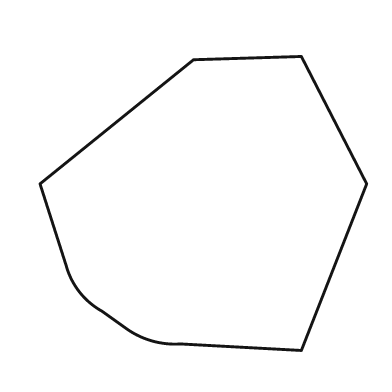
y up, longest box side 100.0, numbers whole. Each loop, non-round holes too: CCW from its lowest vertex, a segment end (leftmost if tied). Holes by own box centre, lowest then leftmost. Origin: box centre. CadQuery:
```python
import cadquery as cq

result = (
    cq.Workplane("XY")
    .moveTo(30.0, -45.0)
    .lineTo(50.0, 6.0)
    .lineTo(30.0, 45.0)
    .lineTo(-3.0, 44.0)
    .lineTo(-50.0, 6.0)
    .lineTo(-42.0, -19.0)
    .threePointArc((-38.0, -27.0), (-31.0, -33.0))
    .lineTo(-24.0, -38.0)
    .threePointArc((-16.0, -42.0), (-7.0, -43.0))
    .close()
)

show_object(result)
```